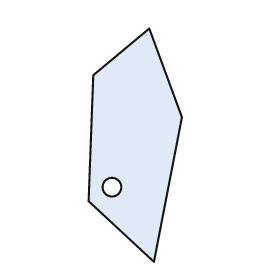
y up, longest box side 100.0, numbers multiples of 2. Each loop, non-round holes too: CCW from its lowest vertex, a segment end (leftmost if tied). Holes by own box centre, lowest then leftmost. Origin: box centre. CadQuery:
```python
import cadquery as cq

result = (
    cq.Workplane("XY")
    .moveTo(8.0, -50.0)
    .lineTo(20.0, 12.0)
    .lineTo(6.0, 50.0)
    .lineTo(-18.0, 30.0)
    .lineTo(-20.0, -24.0)
    .close()
    .moveTo(-10.0, -18.0)
    .circle(4.0)
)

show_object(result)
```